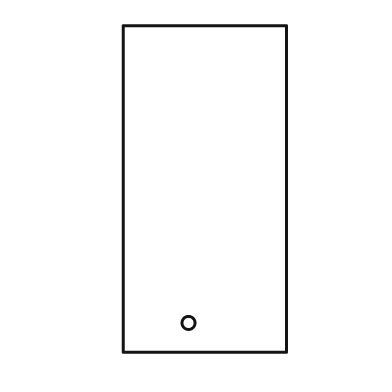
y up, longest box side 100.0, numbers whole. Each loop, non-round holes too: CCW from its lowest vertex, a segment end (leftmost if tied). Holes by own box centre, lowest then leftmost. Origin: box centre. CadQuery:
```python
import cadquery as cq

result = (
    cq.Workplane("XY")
    .moveTo(-25.0, -50.0)
    .lineTo(25.0, -50.0)
    .lineTo(25.0, 50.0)
    .lineTo(-25.0, 50.0)
    .close()
    .moveTo(-5.0, -41.0)
    .circle(2.0)
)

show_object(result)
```